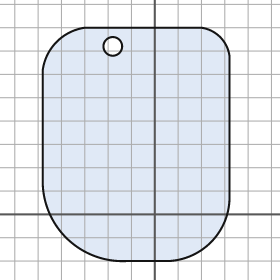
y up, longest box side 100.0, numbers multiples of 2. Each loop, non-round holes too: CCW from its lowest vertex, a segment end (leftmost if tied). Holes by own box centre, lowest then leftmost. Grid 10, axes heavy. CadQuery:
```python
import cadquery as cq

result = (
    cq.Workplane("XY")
    .moveTo(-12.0, -20.0)
    .lineTo(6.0, -20.0)
    .threePointArc((24.0, -12.0), (32.0, 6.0))
    .lineTo(32.0, 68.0)
    .threePointArc((28.0, 76.0), (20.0, 80.0))
    .lineTo(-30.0, 80.0)
    .threePointArc((-42.0, 74.0), (-48.0, 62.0))
    .lineTo(-48.0, 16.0)
    .threePointArc((-38.0, -10.0), (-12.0, -20.0))
    .close()
    .moveTo(-18.0, 72.0)
    .circle(4.0)
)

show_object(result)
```